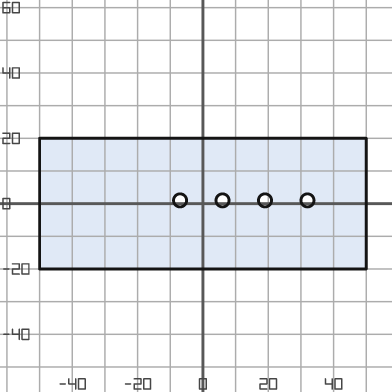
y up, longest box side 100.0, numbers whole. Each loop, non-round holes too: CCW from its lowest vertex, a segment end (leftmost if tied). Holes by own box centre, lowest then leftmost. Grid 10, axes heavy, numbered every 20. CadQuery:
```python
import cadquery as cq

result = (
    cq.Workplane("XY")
    .moveTo(-50.0, -20.0)
    .lineTo(50.0, -20.0)
    .lineTo(50.0, 20.0)
    .lineTo(-50.0, 20.0)
    .close()
    .moveTo(-7.0, 1.0)
    .circle(2.0)
    .moveTo(6.0, 1.0)
    .circle(2.0)
    .moveTo(19.0, 1.0)
    .circle(2.0)
    .moveTo(32.0, 1.0)
    .circle(2.0)
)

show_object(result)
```